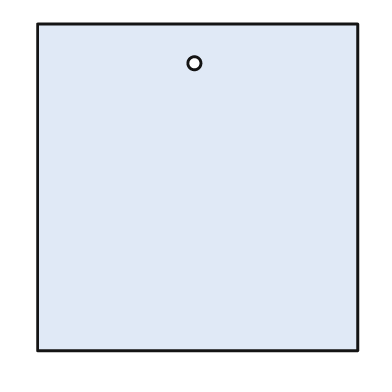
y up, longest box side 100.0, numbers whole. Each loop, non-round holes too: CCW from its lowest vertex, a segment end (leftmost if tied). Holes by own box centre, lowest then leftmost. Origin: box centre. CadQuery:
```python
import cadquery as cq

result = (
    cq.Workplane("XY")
    .moveTo(-49.0, -50.0)
    .lineTo(49.0, -50.0)
    .lineTo(49.0, 50.0)
    .lineTo(-49.0, 50.0)
    .close()
    .moveTo(-1.0, 38.0)
    .circle(2.0)
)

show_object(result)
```